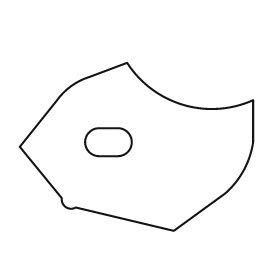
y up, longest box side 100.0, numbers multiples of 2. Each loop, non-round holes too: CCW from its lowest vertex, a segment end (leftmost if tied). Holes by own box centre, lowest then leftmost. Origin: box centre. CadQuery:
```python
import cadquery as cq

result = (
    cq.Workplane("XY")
    .moveTo(16.0, -36.0)
    .lineTo(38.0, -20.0)
    .threePointArc((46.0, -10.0), (50.0, 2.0))
    .lineTo(50.0, 20.0)
    .threePointArc((20.0, 18.0), (-4.0, 36.0))
    .lineTo(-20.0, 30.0)
    .threePointArc((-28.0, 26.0), (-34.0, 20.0))
    .lineTo(-50.0, 0.0)
    .lineTo(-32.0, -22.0)
    .threePointArc((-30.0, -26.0), (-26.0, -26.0))
    .close()
    .moveTo(-16.0, -4.0)
    .lineTo(-8.0, -4.0)
    .threePointArc((-2.0, 2.0), (-8.0, 8.0))
    .lineTo(-16.0, 8.0)
    .threePointArc((-22.0, 2.0), (-16.0, -4.0))
    .close()
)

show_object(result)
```